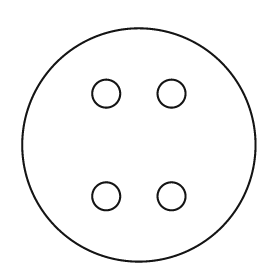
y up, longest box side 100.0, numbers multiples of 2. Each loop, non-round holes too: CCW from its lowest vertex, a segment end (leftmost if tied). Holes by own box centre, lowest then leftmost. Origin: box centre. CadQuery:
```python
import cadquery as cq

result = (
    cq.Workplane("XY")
    .moveTo(0.0, 0.0)
    .circle(50.0)
    .moveTo(-14.0, -22.0)
    .circle(6.0)
    .moveTo(14.0, -22.0)
    .circle(6.0)
    .moveTo(-14.0, 22.0)
    .circle(6.0)
    .moveTo(14.0, 22.0)
    .circle(6.0)
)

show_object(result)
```